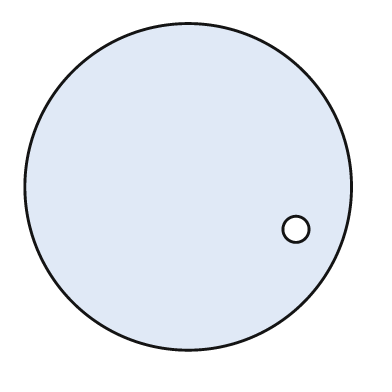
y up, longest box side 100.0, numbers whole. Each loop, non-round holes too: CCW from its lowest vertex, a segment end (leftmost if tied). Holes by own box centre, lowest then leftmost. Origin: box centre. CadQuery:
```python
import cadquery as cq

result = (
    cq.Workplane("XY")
    .moveTo(0.0, 0.0)
    .circle(50.0)
    .moveTo(33.0, -13.0)
    .circle(4.0)
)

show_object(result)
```